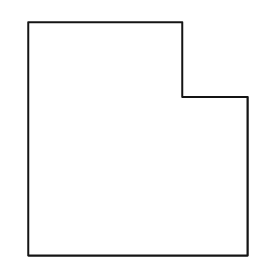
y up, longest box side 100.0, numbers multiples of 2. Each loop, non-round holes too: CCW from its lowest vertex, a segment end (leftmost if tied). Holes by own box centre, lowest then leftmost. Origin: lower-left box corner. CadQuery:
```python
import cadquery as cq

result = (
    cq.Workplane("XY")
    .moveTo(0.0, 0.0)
    .lineTo(94.0, 0.0)
    .lineTo(94.0, 68.0)
    .lineTo(66.0, 68.0)
    .lineTo(66.0, 100.0)
    .lineTo(0.0, 100.0)
    .close()
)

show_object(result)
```